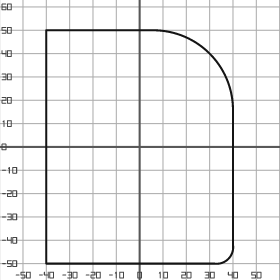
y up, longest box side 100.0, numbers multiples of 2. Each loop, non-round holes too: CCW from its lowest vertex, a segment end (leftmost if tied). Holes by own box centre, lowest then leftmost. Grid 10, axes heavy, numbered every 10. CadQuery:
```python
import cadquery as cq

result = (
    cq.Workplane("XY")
    .moveTo(-40.0, -50.0)
    .lineTo(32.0, -50.0)
    .threePointArc((38.0, -48.0), (40.0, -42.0))
    .lineTo(40.0, 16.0)
    .threePointArc((30.0, 40.0), (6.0, 50.0))
    .lineTo(-40.0, 50.0)
    .close()
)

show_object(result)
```